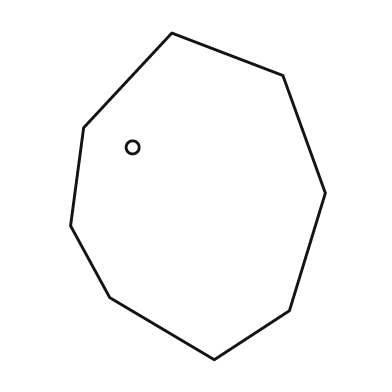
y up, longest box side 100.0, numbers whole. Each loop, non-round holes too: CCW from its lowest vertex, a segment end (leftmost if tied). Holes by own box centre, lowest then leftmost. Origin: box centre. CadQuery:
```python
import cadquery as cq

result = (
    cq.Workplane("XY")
    .moveTo(5.0, -50.0)
    .lineTo(28.0, -35.0)
    .lineTo(39.0, 1.0)
    .lineTo(26.0, 37.0)
    .lineTo(-8.0, 50.0)
    .lineTo(-35.0, 21.0)
    .lineTo(-39.0, -9.0)
    .lineTo(-27.0, -31.0)
    .close()
    .moveTo(-20.0, 15.0)
    .circle(2.0)
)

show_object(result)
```